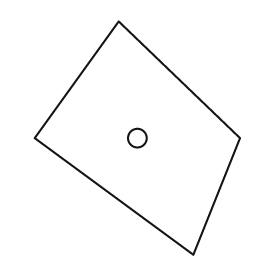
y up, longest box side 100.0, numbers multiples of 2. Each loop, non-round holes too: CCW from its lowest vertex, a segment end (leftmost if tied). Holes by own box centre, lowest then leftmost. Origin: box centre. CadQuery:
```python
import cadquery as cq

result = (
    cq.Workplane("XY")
    .moveTo(24.0, -50.0)
    .lineTo(44.0, 0.0)
    .lineTo(-8.0, 50.0)
    .lineTo(-44.0, 0.0)
    .close()
    .moveTo(0.0, 0.0)
    .circle(4.0)
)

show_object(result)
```